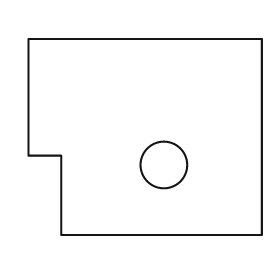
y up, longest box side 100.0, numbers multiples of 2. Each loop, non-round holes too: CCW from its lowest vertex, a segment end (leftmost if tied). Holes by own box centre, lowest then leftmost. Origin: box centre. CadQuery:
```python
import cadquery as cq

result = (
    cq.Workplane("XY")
    .moveTo(-36.0, -42.0)
    .lineTo(50.0, -42.0)
    .lineTo(50.0, 42.0)
    .lineTo(-50.0, 42.0)
    .lineTo(-50.0, -8.0)
    .lineTo(-36.0, -8.0)
    .close()
    .moveTo(8.0, -12.0)
    .circle(10.0)
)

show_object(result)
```